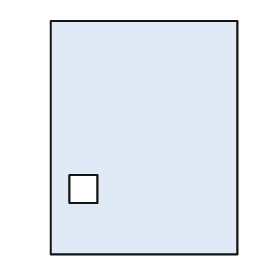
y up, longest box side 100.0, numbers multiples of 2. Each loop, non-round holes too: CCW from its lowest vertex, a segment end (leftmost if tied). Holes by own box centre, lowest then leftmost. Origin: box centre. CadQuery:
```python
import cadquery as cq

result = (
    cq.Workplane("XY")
    .moveTo(-40.0, -50.0)
    .lineTo(40.0, -50.0)
    .lineTo(40.0, 50.0)
    .lineTo(-40.0, 50.0)
    .close()
    .moveTo(-32.0, -28.0)
    .lineTo(-20.0, -28.0)
    .lineTo(-20.0, -16.0)
    .lineTo(-32.0, -16.0)
    .close()
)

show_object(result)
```